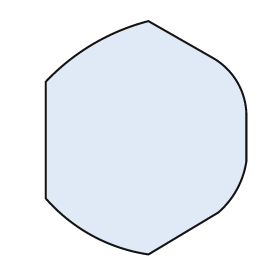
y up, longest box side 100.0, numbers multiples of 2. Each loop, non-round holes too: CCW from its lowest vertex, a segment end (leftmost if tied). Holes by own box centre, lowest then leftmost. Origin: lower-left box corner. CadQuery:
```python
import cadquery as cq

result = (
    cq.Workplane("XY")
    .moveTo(44.0, 0.0)
    .lineTo(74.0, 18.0)
    .threePointArc((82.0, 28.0), (86.0, 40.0))
    .lineTo(86.0, 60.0)
    .threePointArc((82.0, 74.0), (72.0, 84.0))
    .lineTo(44.0, 100.0)
    .threePointArc((20.0, 90.0), (0.0, 74.0))
    .lineTo(0.0, 24.0)
    .threePointArc((20.0, 8.0), (44.0, 0.0))
    .close()
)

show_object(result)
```